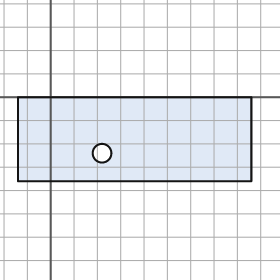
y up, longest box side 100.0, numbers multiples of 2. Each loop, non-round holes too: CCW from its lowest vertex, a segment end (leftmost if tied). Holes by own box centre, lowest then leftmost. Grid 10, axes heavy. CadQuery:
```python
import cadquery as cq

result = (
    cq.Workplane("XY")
    .moveTo(-14.0, -36.0)
    .lineTo(86.0, -36.0)
    .lineTo(86.0, 0.0)
    .lineTo(-14.0, 0.0)
    .close()
    .moveTo(22.0, -24.0)
    .circle(4.0)
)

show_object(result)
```